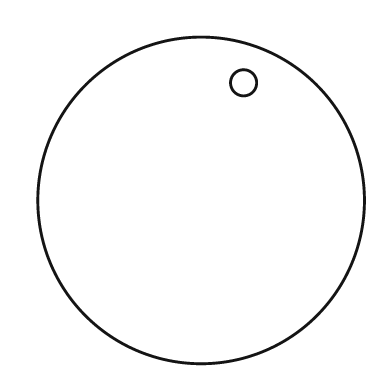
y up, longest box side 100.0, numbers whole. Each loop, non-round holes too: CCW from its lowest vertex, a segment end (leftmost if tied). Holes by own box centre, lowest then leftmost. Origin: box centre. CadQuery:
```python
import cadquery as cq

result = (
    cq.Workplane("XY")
    .moveTo(0.0, 0.0)
    .circle(50.0)
    .moveTo(13.0, 36.0)
    .circle(4.0)
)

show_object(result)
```